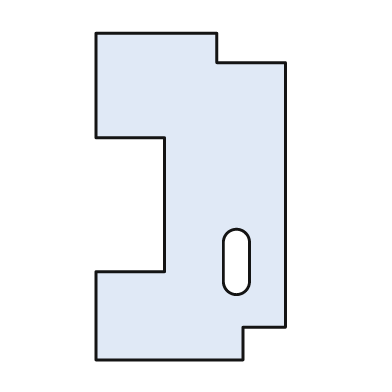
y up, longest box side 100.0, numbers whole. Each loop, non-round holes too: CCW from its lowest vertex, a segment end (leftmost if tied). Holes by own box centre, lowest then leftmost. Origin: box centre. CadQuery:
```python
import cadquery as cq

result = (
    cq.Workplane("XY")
    .moveTo(-29.0, -50.0)
    .lineTo(16.0, -50.0)
    .lineTo(16.0, -40.0)
    .lineTo(29.0, -40.0)
    .lineTo(29.0, 41.0)
    .lineTo(8.0, 41.0)
    .lineTo(8.0, 50.0)
    .lineTo(-29.0, 50.0)
    .lineTo(-29.0, 18.0)
    .lineTo(-8.0, 18.0)
    .lineTo(-8.0, -23.0)
    .lineTo(-29.0, -23.0)
    .close()
    .moveTo(10.0, -26.0)
    .threePointArc((14.0, -30.0), (18.0, -26.0))
    .lineTo(18.0, -14.0)
    .threePointArc((14.0, -10.0), (10.0, -14.0))
    .close()
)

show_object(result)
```